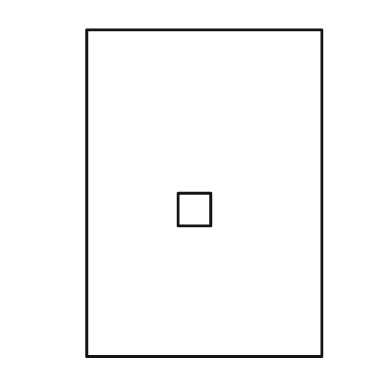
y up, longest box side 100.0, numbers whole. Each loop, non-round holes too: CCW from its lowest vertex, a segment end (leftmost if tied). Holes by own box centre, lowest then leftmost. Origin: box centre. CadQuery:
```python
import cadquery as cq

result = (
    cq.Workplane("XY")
    .moveTo(-36.0, -50.0)
    .lineTo(36.0, -50.0)
    .lineTo(36.0, 50.0)
    .lineTo(-36.0, 50.0)
    .close()
    .moveTo(-8.0, -10.0)
    .lineTo(2.0, -10.0)
    .lineTo(2.0, 0.0)
    .lineTo(-8.0, 0.0)
    .close()
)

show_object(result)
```